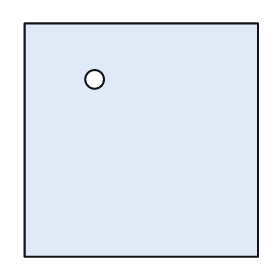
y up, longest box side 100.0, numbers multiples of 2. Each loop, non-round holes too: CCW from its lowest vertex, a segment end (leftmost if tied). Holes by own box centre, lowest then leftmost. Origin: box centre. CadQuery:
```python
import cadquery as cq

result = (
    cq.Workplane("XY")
    .moveTo(-50.0, -50.0)
    .lineTo(50.0, -50.0)
    .lineTo(50.0, 50.0)
    .lineTo(-50.0, 50.0)
    .close()
    .moveTo(-20.0, 26.0)
    .circle(4.0)
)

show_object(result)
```